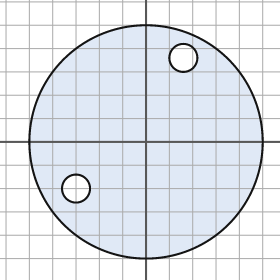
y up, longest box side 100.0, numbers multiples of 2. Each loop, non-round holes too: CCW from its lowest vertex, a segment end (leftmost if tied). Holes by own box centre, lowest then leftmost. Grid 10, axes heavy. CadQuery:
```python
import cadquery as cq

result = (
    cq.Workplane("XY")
    .moveTo(0.0, 0.0)
    .circle(50.0)
    .moveTo(-30.0, -20.0)
    .circle(6.0)
    .moveTo(16.0, 36.0)
    .circle(6.0)
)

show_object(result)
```